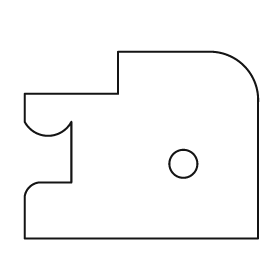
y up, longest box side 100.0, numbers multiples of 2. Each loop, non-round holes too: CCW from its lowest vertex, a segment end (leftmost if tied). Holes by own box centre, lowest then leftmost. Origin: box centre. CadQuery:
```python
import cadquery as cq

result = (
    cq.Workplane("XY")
    .moveTo(-50.0, -40.0)
    .lineTo(50.0, -40.0)
    .lineTo(50.0, 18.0)
    .threePointArc((44.0, 34.0), (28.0, 40.0))
    .lineTo(-10.0, 40.0)
    .lineTo(-10.0, 22.0)
    .lineTo(-50.0, 22.0)
    .lineTo(-50.0, 10.0)
    .threePointArc((-40.0, 4.0), (-30.0, 10.0))
    .lineTo(-30.0, -16.0)
    .lineTo(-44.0, -16.0)
    .threePointArc((-48.0, -18.0), (-50.0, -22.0))
    .close()
    .moveTo(18.0, -8.0)
    .circle(6.0)
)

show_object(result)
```